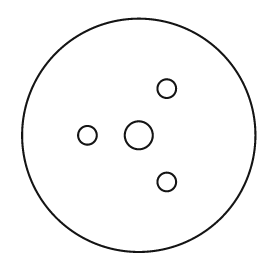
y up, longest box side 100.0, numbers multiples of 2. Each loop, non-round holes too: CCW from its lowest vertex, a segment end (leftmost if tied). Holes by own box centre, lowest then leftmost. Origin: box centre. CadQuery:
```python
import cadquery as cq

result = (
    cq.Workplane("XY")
    .moveTo(0.0, 0.0)
    .circle(50.0)
    .moveTo(12.0, -20.0)
    .circle(4.0)
    .moveTo(-22.0, 0.0)
    .circle(4.0)
    .moveTo(0.0, 0.0)
    .circle(6.0)
    .moveTo(12.0, 20.0)
    .circle(4.0)
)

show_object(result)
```